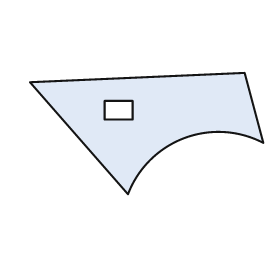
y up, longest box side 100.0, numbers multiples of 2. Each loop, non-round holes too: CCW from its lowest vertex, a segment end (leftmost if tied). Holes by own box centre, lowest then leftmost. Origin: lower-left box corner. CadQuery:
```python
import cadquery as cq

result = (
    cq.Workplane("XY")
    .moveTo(42.0, 0.0)
    .threePointArc((66.0, 24.0), (100.0, 22.0))
    .lineTo(92.0, 52.0)
    .lineTo(0.0, 48.0)
    .close()
    .moveTo(32.0, 32.0)
    .lineTo(44.0, 32.0)
    .lineTo(44.0, 40.0)
    .lineTo(32.0, 40.0)
    .close()
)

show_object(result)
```